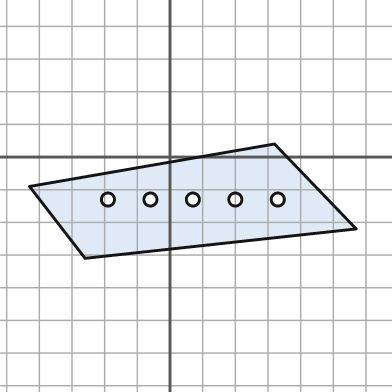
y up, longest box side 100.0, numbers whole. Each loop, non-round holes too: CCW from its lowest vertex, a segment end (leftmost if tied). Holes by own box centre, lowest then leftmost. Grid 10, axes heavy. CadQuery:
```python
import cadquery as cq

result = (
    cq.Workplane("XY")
    .moveTo(-26.0, -31.0)
    .lineTo(57.0, -22.0)
    .lineTo(32.0, 4.0)
    .lineTo(-43.0, -9.0)
    .close()
    .moveTo(-19.0, -13.0)
    .circle(2.0)
    .moveTo(-6.0, -13.0)
    .circle(2.0)
    .moveTo(7.0, -13.0)
    .circle(2.0)
    .moveTo(20.0, -13.0)
    .circle(2.0)
    .moveTo(33.0, -13.0)
    .circle(2.0)
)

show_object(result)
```